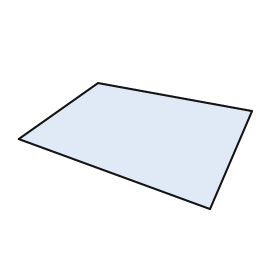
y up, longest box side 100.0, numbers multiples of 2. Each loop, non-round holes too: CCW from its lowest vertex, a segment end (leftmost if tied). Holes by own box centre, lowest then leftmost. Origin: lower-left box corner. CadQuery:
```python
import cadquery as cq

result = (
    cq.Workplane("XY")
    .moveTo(82.0, 0.0)
    .lineTo(100.0, 42.0)
    .lineTo(34.0, 54.0)
    .lineTo(0.0, 30.0)
    .close()
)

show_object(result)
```